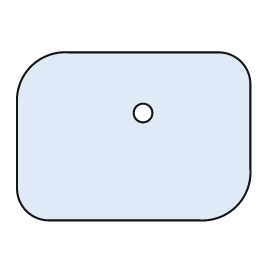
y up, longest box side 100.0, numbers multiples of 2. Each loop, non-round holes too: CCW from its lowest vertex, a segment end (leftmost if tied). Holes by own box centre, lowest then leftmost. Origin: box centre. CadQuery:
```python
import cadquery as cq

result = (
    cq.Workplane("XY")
    .moveTo(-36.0, -36.0)
    .lineTo(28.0, -36.0)
    .threePointArc((44.0, -30.0), (50.0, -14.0))
    .lineTo(50.0, 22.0)
    .threePointArc((46.0, 32.0), (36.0, 36.0))
    .lineTo(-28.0, 36.0)
    .threePointArc((-44.0, 30.0), (-50.0, 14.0))
    .lineTo(-50.0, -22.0)
    .threePointArc((-46.0, -32.0), (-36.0, -36.0))
    .close()
    .moveTo(4.0, 10.0)
    .circle(4.0)
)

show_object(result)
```